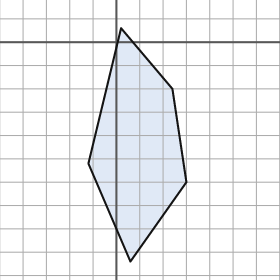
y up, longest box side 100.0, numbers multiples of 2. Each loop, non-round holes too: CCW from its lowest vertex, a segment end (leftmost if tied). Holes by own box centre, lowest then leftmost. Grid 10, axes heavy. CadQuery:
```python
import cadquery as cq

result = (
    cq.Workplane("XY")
    .moveTo(6.0, -94.0)
    .lineTo(30.0, -60.0)
    .lineTo(24.0, -20.0)
    .lineTo(2.0, 6.0)
    .lineTo(-12.0, -52.0)
    .close()
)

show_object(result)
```